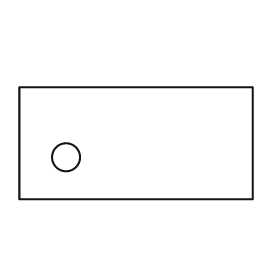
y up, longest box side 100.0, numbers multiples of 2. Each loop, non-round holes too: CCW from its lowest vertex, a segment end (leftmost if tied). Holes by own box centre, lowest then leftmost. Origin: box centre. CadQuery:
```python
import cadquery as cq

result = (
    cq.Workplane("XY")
    .moveTo(-50.0, -24.0)
    .lineTo(50.0, -24.0)
    .lineTo(50.0, 24.0)
    .lineTo(-50.0, 24.0)
    .close()
    .moveTo(-30.0, -6.0)
    .circle(6.0)
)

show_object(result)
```